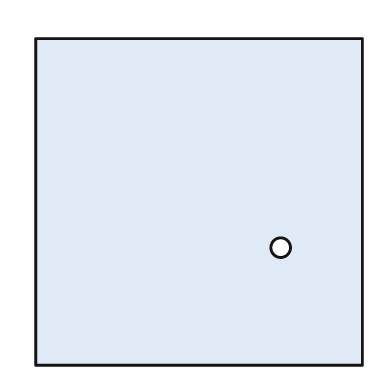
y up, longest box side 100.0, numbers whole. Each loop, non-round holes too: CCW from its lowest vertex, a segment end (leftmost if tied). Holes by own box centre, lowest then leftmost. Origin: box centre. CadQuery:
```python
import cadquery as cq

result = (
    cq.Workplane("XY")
    .moveTo(-50.0, -50.0)
    .lineTo(50.0, -50.0)
    .lineTo(50.0, 50.0)
    .lineTo(-50.0, 50.0)
    .close()
    .moveTo(25.0, -14.0)
    .circle(3.0)
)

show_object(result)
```